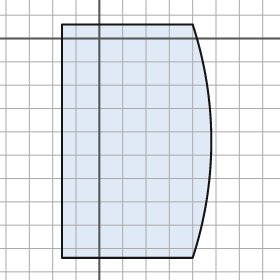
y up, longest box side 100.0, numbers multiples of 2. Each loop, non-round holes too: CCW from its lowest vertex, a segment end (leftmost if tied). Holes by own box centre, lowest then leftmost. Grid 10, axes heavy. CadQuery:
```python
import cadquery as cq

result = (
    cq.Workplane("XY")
    .moveTo(-16.0, -94.0)
    .lineTo(40.0, -94.0)
    .threePointArc((48.0, -44.0), (40.0, 6.0))
    .lineTo(-16.0, 6.0)
    .close()
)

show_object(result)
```